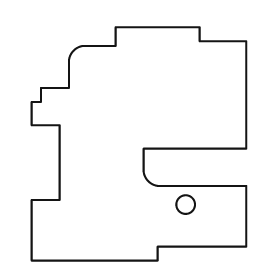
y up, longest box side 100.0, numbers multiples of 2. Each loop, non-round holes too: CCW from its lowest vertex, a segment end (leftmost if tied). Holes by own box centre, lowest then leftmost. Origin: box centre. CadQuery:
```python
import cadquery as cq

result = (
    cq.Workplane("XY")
    .moveTo(-46.0, -50.0)
    .lineTo(8.0, -50.0)
    .lineTo(8.0, -44.0)
    .lineTo(46.0, -44.0)
    .lineTo(46.0, -18.0)
    .lineTo(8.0, -18.0)
    .threePointArc((4.0, -16.0), (2.0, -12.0))
    .lineTo(2.0, -2.0)
    .lineTo(46.0, -2.0)
    .lineTo(46.0, 44.0)
    .lineTo(26.0, 44.0)
    .lineTo(26.0, 50.0)
    .lineTo(-10.0, 50.0)
    .lineTo(-10.0, 42.0)
    .lineTo(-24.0, 42.0)
    .threePointArc((-28.0, 40.0), (-30.0, 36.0))
    .lineTo(-30.0, 24.0)
    .lineTo(-42.0, 24.0)
    .lineTo(-42.0, 18.0)
    .lineTo(-46.0, 18.0)
    .lineTo(-46.0, 8.0)
    .lineTo(-34.0, 8.0)
    .lineTo(-34.0, -24.0)
    .lineTo(-46.0, -24.0)
    .close()
    .moveTo(20.0, -26.0)
    .circle(4.0)
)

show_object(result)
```